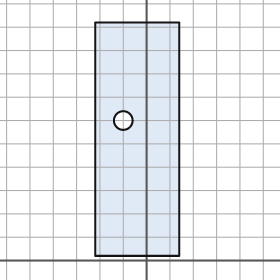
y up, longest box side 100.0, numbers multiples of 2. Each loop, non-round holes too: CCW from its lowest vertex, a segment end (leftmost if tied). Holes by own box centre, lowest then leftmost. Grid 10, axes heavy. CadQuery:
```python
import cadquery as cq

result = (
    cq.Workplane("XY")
    .moveTo(-22.0, 2.0)
    .lineTo(14.0, 2.0)
    .lineTo(14.0, 102.0)
    .lineTo(-22.0, 102.0)
    .close()
    .moveTo(-10.0, 60.0)
    .circle(4.0)
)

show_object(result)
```